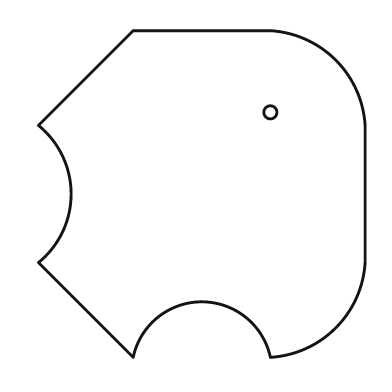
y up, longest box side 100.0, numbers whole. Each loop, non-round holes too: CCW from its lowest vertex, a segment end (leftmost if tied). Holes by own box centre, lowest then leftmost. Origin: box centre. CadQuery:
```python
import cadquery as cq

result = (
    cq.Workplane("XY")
    .moveTo(-21.0, -50.0)
    .threePointArc((0.0, -33.0), (21.0, -50.0))
    .threePointArc((41.0, -41.0), (50.0, -21.0))
    .lineTo(50.0, 21.0)
    .threePointArc((41.0, 41.0), (21.0, 50.0))
    .lineTo(-21.0, 50.0)
    .lineTo(-50.0, 21.0)
    .threePointArc((-40.0, 0.0), (-50.0, -21.0))
    .close()
    .moveTo(21.0, 25.0)
    .circle(2.0)
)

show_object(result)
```